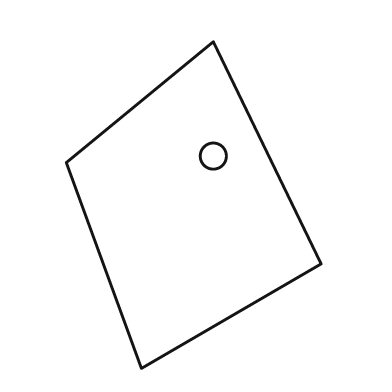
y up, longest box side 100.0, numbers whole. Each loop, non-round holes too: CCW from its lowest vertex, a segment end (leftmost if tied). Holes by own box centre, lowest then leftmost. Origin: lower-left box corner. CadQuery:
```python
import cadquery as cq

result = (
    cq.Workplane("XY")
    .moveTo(23.0, 0.0)
    .lineTo(78.0, 32.0)
    .lineTo(45.0, 100.0)
    .lineTo(0.0, 63.0)
    .close()
    .moveTo(45.0, 65.0)
    .circle(4.0)
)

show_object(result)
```